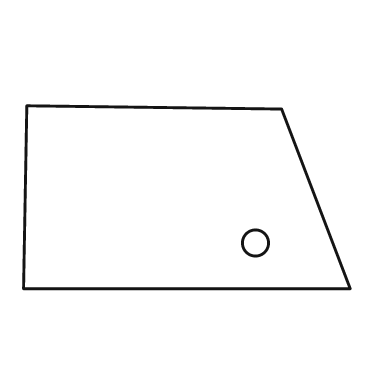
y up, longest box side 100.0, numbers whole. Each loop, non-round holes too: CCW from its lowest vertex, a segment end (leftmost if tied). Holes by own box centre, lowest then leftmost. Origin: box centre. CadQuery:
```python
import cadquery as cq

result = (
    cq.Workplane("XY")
    .moveTo(-50.0, -28.0)
    .lineTo(50.0, -28.0)
    .lineTo(29.0, 27.0)
    .lineTo(-49.0, 28.0)
    .close()
    .moveTo(21.0, -14.0)
    .circle(4.0)
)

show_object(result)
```